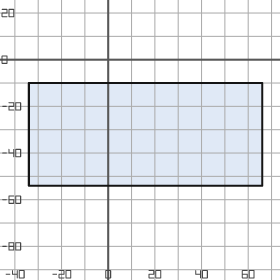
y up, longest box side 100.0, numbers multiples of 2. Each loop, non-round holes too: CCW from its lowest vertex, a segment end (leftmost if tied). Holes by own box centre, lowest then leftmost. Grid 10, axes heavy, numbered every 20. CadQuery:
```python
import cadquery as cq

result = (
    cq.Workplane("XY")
    .moveTo(-34.0, -54.0)
    .lineTo(66.0, -54.0)
    .lineTo(66.0, -10.0)
    .lineTo(-34.0, -10.0)
    .close()
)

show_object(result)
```